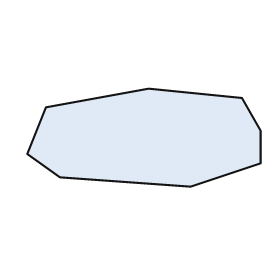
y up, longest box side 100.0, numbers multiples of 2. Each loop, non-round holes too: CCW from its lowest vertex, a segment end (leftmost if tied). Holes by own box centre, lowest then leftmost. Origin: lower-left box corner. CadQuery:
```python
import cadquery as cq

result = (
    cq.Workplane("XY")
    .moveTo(70.0, 0.0)
    .lineTo(100.0, 10.0)
    .lineTo(100.0, 24.0)
    .lineTo(92.0, 38.0)
    .lineTo(52.0, 42.0)
    .lineTo(8.0, 34.0)
    .lineTo(0.0, 14.0)
    .lineTo(14.0, 4.0)
    .close()
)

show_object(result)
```